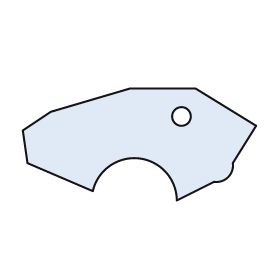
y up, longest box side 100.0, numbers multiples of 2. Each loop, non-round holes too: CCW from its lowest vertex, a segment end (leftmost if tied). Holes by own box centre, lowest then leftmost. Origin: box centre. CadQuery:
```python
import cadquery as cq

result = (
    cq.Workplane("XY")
    .moveTo(16.0, -24.0)
    .lineTo(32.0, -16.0)
    .threePointArc((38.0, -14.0), (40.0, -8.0))
    .lineTo(50.0, 8.0)
    .lineTo(24.0, 24.0)
    .lineTo(-4.0, 24.0)
    .lineTo(-38.0, 14.0)
    .lineTo(-50.0, 6.0)
    .lineTo(-48.0, -8.0)
    .lineTo(-20.0, -20.0)
    .threePointArc((0.0, -6.0), (16.0, -24.0))
    .close()
    .moveTo(18.0, 12.0)
    .circle(4.0)
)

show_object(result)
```